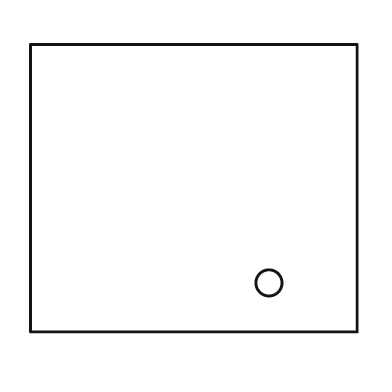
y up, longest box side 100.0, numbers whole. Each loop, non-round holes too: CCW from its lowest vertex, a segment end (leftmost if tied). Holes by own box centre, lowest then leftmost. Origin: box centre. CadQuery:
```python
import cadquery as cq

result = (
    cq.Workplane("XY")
    .moveTo(-50.0, -44.0)
    .lineTo(50.0, -44.0)
    .lineTo(50.0, 44.0)
    .lineTo(-50.0, 44.0)
    .close()
    .moveTo(23.0, -29.0)
    .circle(4.0)
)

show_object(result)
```